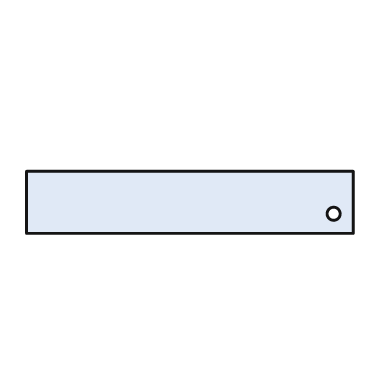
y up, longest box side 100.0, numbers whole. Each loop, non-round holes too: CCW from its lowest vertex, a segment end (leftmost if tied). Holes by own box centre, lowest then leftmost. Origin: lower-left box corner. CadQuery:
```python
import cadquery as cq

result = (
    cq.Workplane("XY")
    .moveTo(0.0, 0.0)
    .lineTo(100.0, 0.0)
    .lineTo(100.0, 19.0)
    .lineTo(0.0, 19.0)
    .close()
    .moveTo(94.0, 6.0)
    .circle(2.0)
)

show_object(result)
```